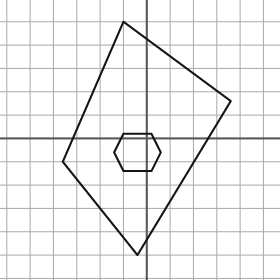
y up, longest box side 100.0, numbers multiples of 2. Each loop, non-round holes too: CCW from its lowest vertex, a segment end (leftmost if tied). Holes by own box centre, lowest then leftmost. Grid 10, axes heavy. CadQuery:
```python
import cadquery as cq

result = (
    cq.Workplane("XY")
    .moveTo(-4.0, -50.0)
    .lineTo(36.0, 16.0)
    .lineTo(-10.0, 50.0)
    .lineTo(-36.0, -10.0)
    .close()
    .moveTo(-10.0, -14.0)
    .lineTo(2.0, -14.0)
    .lineTo(6.0, -6.0)
    .lineTo(2.0, 2.0)
    .lineTo(-10.0, 2.0)
    .lineTo(-14.0, -6.0)
    .close()
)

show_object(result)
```